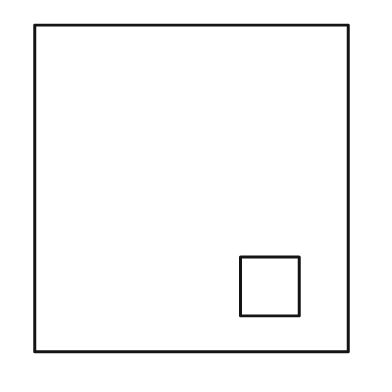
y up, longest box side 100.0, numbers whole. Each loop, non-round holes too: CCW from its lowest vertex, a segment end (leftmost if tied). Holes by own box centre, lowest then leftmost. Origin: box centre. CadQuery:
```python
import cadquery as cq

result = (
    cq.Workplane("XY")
    .moveTo(-48.0, -50.0)
    .lineTo(48.0, -50.0)
    .lineTo(48.0, 50.0)
    .lineTo(-48.0, 50.0)
    .close()
    .moveTo(15.0, -39.0)
    .lineTo(33.0, -39.0)
    .lineTo(33.0, -21.0)
    .lineTo(15.0, -21.0)
    .close()
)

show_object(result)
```